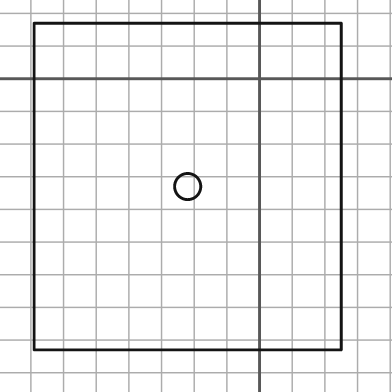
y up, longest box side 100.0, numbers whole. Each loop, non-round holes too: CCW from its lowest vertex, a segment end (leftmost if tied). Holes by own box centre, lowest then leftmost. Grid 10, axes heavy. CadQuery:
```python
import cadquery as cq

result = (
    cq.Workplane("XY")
    .moveTo(-69.0, -83.0)
    .lineTo(25.0, -83.0)
    .lineTo(25.0, 17.0)
    .lineTo(-69.0, 17.0)
    .close()
    .moveTo(-22.0, -33.0)
    .circle(4.0)
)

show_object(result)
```